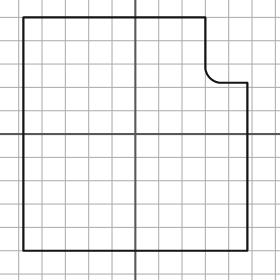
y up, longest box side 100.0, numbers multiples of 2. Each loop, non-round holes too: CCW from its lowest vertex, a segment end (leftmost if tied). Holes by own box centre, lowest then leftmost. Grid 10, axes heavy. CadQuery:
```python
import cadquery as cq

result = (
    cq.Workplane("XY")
    .moveTo(-48.0, -50.0)
    .lineTo(48.0, -50.0)
    .lineTo(48.0, 22.0)
    .lineTo(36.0, 22.0)
    .threePointArc((32.0, 24.0), (30.0, 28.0))
    .lineTo(30.0, 50.0)
    .lineTo(-48.0, 50.0)
    .close()
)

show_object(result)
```